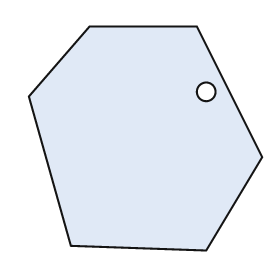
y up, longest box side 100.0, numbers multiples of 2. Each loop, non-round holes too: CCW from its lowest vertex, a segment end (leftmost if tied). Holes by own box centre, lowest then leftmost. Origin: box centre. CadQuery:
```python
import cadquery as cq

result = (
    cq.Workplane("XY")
    .moveTo(26.0, -48.0)
    .lineTo(50.0, -8.0)
    .lineTo(22.0, 48.0)
    .lineTo(-24.0, 48.0)
    .lineTo(-50.0, 18.0)
    .lineTo(-32.0, -46.0)
    .close()
    .moveTo(26.0, 20.0)
    .circle(4.0)
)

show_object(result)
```